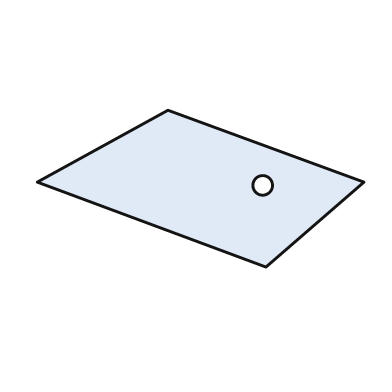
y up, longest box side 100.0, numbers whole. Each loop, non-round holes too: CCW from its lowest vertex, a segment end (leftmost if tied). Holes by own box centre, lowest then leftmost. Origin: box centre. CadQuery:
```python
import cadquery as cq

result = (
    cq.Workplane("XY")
    .moveTo(20.0, -24.0)
    .lineTo(50.0, 2.0)
    .lineTo(-10.0, 24.0)
    .lineTo(-50.0, 2.0)
    .close()
    .moveTo(19.0, 1.0)
    .circle(3.0)
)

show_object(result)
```